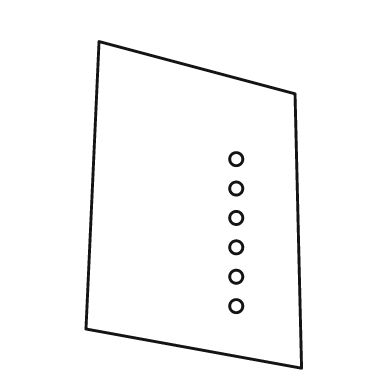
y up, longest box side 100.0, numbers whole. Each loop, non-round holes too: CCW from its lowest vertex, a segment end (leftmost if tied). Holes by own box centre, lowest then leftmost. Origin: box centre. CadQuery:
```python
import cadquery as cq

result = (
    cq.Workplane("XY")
    .moveTo(33.0, -50.0)
    .lineTo(31.0, 34.0)
    .lineTo(-29.0, 50.0)
    .lineTo(-33.0, -38.0)
    .close()
    .moveTo(13.0, -31.0)
    .circle(2.0)
    .moveTo(13.0, -22.0)
    .circle(2.0)
    .moveTo(13.0, -13.0)
    .circle(2.0)
    .moveTo(13.0, -4.0)
    .circle(2.0)
    .moveTo(13.0, 5.0)
    .circle(2.0)
    .moveTo(13.0, 14.0)
    .circle(2.0)
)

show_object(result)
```